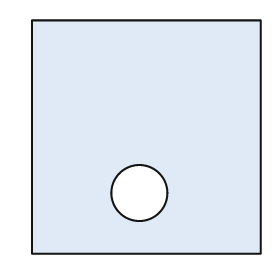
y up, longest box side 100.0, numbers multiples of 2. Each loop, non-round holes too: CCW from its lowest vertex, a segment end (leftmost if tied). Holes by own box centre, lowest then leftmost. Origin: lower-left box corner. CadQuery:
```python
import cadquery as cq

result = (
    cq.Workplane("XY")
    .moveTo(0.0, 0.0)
    .lineTo(98.0, 0.0)
    .lineTo(98.0, 100.0)
    .lineTo(0.0, 100.0)
    .close()
    .moveTo(46.0, 26.0)
    .circle(12.0)
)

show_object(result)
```